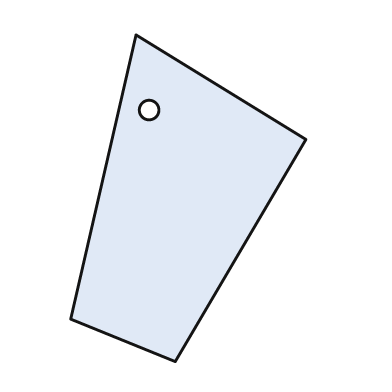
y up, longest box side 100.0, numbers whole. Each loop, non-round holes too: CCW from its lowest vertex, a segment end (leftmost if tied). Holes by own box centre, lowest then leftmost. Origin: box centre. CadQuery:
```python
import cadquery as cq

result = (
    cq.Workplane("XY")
    .moveTo(-4.0, -50.0)
    .lineTo(36.0, 18.0)
    .lineTo(-16.0, 50.0)
    .lineTo(-36.0, -37.0)
    .close()
    .moveTo(-12.0, 27.0)
    .circle(3.0)
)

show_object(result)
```